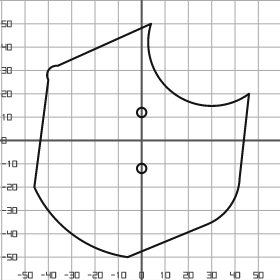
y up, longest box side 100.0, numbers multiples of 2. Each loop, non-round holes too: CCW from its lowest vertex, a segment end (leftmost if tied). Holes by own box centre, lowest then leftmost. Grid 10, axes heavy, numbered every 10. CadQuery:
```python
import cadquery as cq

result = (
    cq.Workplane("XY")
    .moveTo(-6.0, -50.0)
    .lineTo(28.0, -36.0)
    .threePointArc((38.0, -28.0), (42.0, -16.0))
    .lineTo(46.0, 20.0)
    .threePointArc((14.0, 20.0), (4.0, 50.0))
    .lineTo(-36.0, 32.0)
    .threePointArc((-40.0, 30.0), (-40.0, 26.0))
    .lineTo(-46.0, -20.0)
    .threePointArc((-30.0, -40.0), (-6.0, -50.0))
    .close()
    .moveTo(0.0, -12.0)
    .circle(2.0)
    .moveTo(0.0, 12.0)
    .circle(2.0)
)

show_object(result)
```